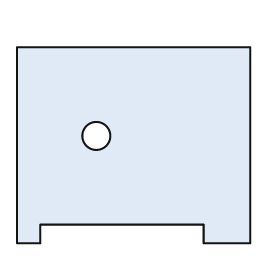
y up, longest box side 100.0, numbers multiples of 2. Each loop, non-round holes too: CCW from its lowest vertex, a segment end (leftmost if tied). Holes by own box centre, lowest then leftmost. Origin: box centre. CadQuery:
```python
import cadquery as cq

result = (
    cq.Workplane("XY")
    .moveTo(-50.0, -42.0)
    .lineTo(-40.0, -42.0)
    .lineTo(-40.0, -34.0)
    .lineTo(30.0, -34.0)
    .lineTo(30.0, -42.0)
    .lineTo(50.0, -42.0)
    .lineTo(50.0, 42.0)
    .lineTo(-50.0, 42.0)
    .close()
    .moveTo(-16.0, 4.0)
    .circle(6.0)
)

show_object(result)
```